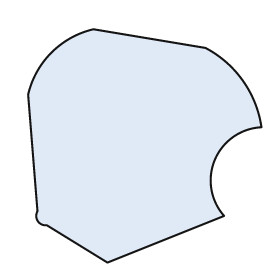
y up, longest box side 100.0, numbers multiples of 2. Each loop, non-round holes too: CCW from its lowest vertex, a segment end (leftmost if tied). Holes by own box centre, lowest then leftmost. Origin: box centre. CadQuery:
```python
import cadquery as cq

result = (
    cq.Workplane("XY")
    .moveTo(-16.0, -50.0)
    .lineTo(34.0, -30.0)
    .threePointArc((30.0, -6.0), (50.0, 8.0))
    .threePointArc((42.0, 28.0), (26.0, 42.0))
    .lineTo(-22.0, 50.0)
    .threePointArc((-40.0, 40.0), (-50.0, 22.0))
    .lineTo(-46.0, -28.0)
    .threePointArc((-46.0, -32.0), (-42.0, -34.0))
    .close()
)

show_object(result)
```